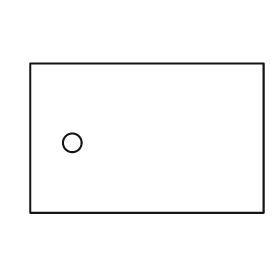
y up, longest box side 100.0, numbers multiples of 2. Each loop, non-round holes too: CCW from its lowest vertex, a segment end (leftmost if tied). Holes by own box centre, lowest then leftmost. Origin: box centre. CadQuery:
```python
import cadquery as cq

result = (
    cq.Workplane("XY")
    .moveTo(-50.0, -32.0)
    .lineTo(50.0, -32.0)
    .lineTo(50.0, 32.0)
    .lineTo(-50.0, 32.0)
    .close()
    .moveTo(-32.0, -2.0)
    .circle(4.0)
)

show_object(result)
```